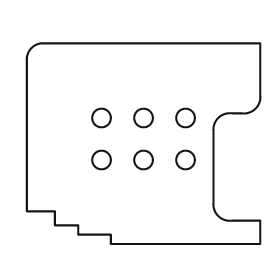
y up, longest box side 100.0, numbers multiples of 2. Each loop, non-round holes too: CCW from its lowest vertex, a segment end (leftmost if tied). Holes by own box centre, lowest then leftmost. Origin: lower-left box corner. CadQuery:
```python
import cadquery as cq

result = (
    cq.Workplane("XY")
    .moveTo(36.0, 0.0)
    .lineTo(100.0, 0.0)
    .lineTo(100.0, 10.0)
    .lineTo(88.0, 10.0)
    .threePointArc((82.0, 12.0), (80.0, 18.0))
    .lineTo(80.0, 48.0)
    .threePointArc((82.0, 54.0), (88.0, 56.0))
    .lineTo(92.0, 56.0)
    .threePointArc((98.0, 58.0), (100.0, 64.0))
    .lineTo(100.0, 86.0)
    .lineTo(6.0, 86.0)
    .threePointArc((2.0, 84.0), (0.0, 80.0))
    .lineTo(0.0, 14.0)
    .lineTo(12.0, 14.0)
    .lineTo(12.0, 8.0)
    .lineTo(22.0, 8.0)
    .lineTo(22.0, 4.0)
    .lineTo(36.0, 4.0)
    .close()
    .moveTo(32.0, 36.0)
    .circle(4.0)
    .moveTo(50.0, 36.0)
    .circle(4.0)
    .moveTo(68.0, 36.0)
    .circle(4.0)
    .moveTo(32.0, 54.0)
    .circle(4.0)
    .moveTo(50.0, 54.0)
    .circle(4.0)
    .moveTo(68.0, 54.0)
    .circle(4.0)
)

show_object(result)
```